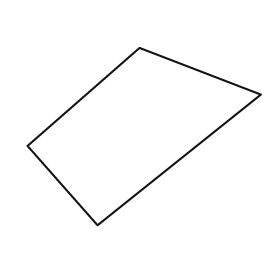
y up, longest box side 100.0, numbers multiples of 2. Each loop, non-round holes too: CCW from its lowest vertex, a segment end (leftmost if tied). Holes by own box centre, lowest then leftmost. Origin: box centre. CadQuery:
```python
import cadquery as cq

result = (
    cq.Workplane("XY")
    .moveTo(-20.0, -38.0)
    .lineTo(50.0, 18.0)
    .lineTo(-2.0, 38.0)
    .lineTo(-50.0, -4.0)
    .close()
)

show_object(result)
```